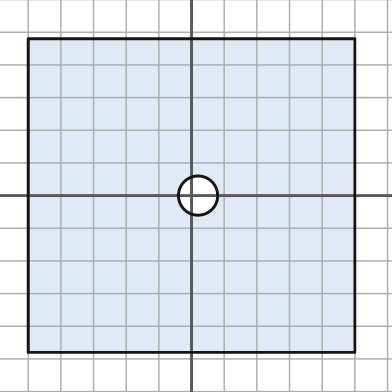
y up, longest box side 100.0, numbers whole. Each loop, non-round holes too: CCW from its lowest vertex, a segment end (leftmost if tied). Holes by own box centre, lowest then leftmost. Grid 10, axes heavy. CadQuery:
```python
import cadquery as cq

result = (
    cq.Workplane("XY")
    .moveTo(-50.0, -48.0)
    .lineTo(50.0, -48.0)
    .lineTo(50.0, 48.0)
    .lineTo(-50.0, 48.0)
    .close()
    .moveTo(2.0, 0.0)
    .circle(6.0)
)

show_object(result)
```